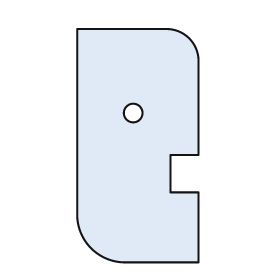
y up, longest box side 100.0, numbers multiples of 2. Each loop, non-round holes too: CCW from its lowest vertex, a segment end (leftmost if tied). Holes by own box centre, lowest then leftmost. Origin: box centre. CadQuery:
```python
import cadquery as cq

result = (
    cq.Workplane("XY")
    .moveTo(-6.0, -50.0)
    .lineTo(26.0, -50.0)
    .lineTo(26.0, -20.0)
    .lineTo(14.0, -20.0)
    .lineTo(14.0, -4.0)
    .lineTo(26.0, -4.0)
    .lineTo(26.0, 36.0)
    .threePointArc((22.0, 46.0), (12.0, 50.0))
    .lineTo(-26.0, 50.0)
    .lineTo(-26.0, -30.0)
    .threePointArc((-20.0, -44.0), (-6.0, -50.0))
    .close()
    .moveTo(-2.0, 14.0)
    .circle(4.0)
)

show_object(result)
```